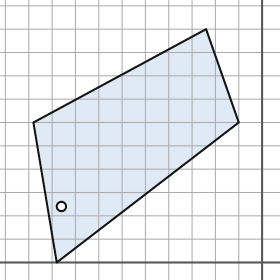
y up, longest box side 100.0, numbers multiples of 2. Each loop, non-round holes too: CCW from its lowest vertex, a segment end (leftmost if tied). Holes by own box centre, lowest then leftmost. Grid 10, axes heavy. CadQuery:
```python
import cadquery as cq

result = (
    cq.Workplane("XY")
    .moveTo(-88.0, 0.0)
    .lineTo(-10.0, 60.0)
    .lineTo(-24.0, 100.0)
    .lineTo(-98.0, 60.0)
    .close()
    .moveTo(-86.0, 24.0)
    .circle(2.0)
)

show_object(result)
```